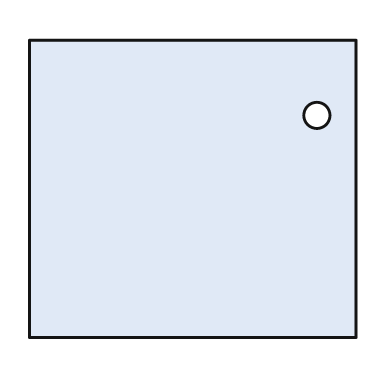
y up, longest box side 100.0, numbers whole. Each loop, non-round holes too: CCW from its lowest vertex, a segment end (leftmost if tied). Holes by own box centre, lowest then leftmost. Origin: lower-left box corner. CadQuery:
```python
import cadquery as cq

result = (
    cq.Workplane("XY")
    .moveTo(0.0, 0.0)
    .lineTo(100.0, 0.0)
    .lineTo(100.0, 91.0)
    .lineTo(0.0, 91.0)
    .close()
    .moveTo(88.0, 68.0)
    .circle(4.0)
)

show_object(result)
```